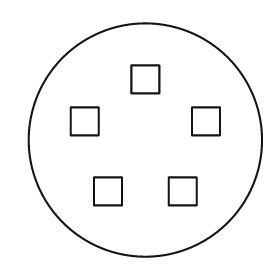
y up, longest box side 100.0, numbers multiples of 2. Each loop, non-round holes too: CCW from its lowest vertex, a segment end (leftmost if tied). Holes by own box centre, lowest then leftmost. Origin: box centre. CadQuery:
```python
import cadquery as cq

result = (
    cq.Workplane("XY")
    .moveTo(0.0, 0.0)
    .circle(50.0)
    .moveTo(-22.0, -28.0)
    .lineTo(-10.0, -28.0)
    .lineTo(-10.0, -16.0)
    .lineTo(-22.0, -16.0)
    .close()
    .moveTo(10.0, -28.0)
    .lineTo(22.0, -28.0)
    .lineTo(22.0, -16.0)
    .lineTo(10.0, -16.0)
    .close()
    .moveTo(-32.0, 2.0)
    .lineTo(-20.0, 2.0)
    .lineTo(-20.0, 14.0)
    .lineTo(-32.0, 14.0)
    .close()
    .moveTo(20.0, 2.0)
    .lineTo(32.0, 2.0)
    .lineTo(32.0, 14.0)
    .lineTo(20.0, 14.0)
    .close()
    .moveTo(-6.0, 20.0)
    .lineTo(6.0, 20.0)
    .lineTo(6.0, 32.0)
    .lineTo(-6.0, 32.0)
    .close()
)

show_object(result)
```